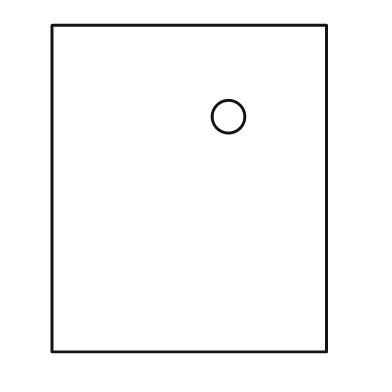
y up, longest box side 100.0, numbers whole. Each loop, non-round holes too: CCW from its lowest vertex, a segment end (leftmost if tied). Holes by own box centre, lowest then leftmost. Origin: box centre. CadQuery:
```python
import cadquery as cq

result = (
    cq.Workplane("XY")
    .moveTo(-42.0, -50.0)
    .lineTo(42.0, -50.0)
    .lineTo(42.0, 50.0)
    .lineTo(-42.0, 50.0)
    .close()
    .moveTo(12.0, 22.0)
    .circle(5.0)
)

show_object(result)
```